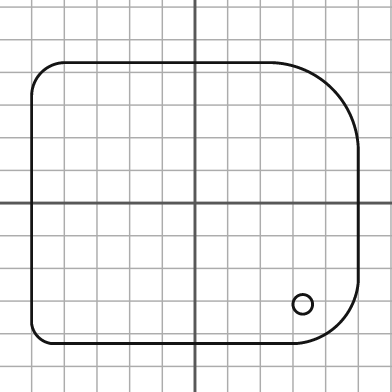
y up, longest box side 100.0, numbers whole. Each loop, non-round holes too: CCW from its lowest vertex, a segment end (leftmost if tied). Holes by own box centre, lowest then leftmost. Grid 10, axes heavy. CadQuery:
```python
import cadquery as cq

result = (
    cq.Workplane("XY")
    .moveTo(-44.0, -43.0)
    .lineTo(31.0, -43.0)
    .threePointArc((44.0, -37.0), (50.0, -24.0))
    .lineTo(50.0, 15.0)
    .threePointArc((42.0, 35.0), (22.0, 43.0))
    .lineTo(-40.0, 43.0)
    .threePointArc((-47.0, 40.0), (-50.0, 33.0))
    .lineTo(-50.0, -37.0)
    .threePointArc((-48.0, -41.0), (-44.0, -43.0))
    .close()
    .moveTo(33.0, -31.0)
    .circle(3.0)
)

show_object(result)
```